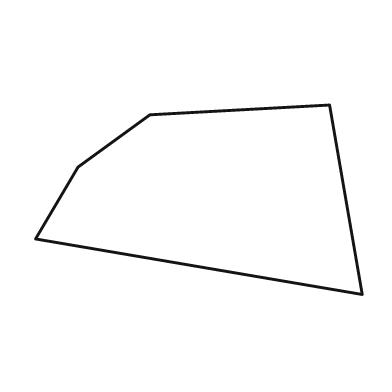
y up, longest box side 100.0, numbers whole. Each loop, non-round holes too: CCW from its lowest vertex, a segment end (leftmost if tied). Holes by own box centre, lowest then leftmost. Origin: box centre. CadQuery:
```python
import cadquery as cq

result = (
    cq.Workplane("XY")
    .moveTo(50.0, -29.0)
    .lineTo(40.0, 29.0)
    .lineTo(-15.0, 26.0)
    .lineTo(-37.0, 10.0)
    .lineTo(-50.0, -12.0)
    .close()
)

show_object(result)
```